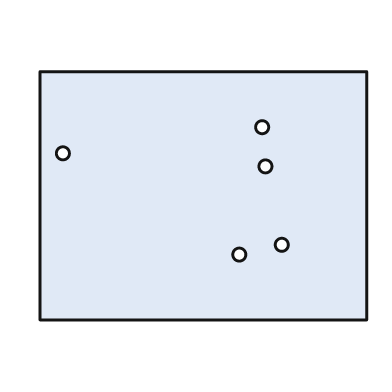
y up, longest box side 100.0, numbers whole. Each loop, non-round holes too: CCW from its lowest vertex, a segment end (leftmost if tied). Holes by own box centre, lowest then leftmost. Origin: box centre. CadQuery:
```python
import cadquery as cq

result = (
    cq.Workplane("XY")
    .moveTo(-50.0, -38.0)
    .lineTo(50.0, -38.0)
    .lineTo(50.0, 38.0)
    .lineTo(-50.0, 38.0)
    .close()
    .moveTo(11.0, -18.0)
    .circle(2.0)
    .moveTo(24.0, -15.0)
    .circle(2.0)
    .moveTo(19.0, 9.0)
    .circle(2.0)
    .moveTo(-43.0, 13.0)
    .circle(2.0)
    .moveTo(18.0, 21.0)
    .circle(2.0)
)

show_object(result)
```